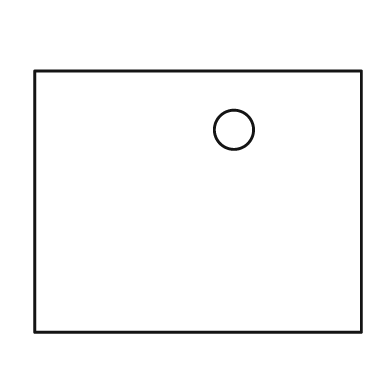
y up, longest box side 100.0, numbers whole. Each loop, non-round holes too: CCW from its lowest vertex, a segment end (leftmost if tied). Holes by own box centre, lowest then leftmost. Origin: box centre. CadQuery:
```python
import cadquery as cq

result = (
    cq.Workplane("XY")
    .moveTo(-50.0, -40.0)
    .lineTo(50.0, -40.0)
    .lineTo(50.0, 40.0)
    .lineTo(-50.0, 40.0)
    .close()
    .moveTo(11.0, 22.0)
    .circle(6.0)
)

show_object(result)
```